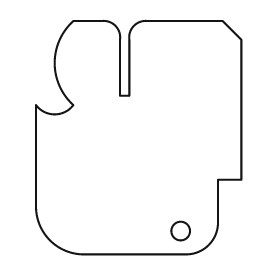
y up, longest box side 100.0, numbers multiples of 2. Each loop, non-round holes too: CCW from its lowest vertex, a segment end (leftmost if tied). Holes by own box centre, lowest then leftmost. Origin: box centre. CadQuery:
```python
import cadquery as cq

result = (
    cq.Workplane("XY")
    .moveTo(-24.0, -50.0)
    .lineTo(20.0, -50.0)
    .threePointArc((30.0, -46.0), (34.0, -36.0))
    .lineTo(34.0, -18.0)
    .lineTo(44.0, -18.0)
    .lineTo(44.0, 42.0)
    .lineTo(36.0, 50.0)
    .lineTo(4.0, 50.0)
    .threePointArc((-2.0, 48.0), (-4.0, 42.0))
    .lineTo(-4.0, 18.0)
    .lineTo(-8.0, 18.0)
    .lineTo(-8.0, 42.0)
    .threePointArc((-10.0, 48.0), (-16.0, 50.0))
    .lineTo(-28.0, 50.0)
    .threePointArc((-36.0, 32.0), (-28.0, 14.0))
    .threePointArc((-36.0, 10.0), (-44.0, 14.0))
    .lineTo(-44.0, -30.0)
    .threePointArc((-38.0, -44.0), (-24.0, -50.0))
    .close()
    .moveTo(18.0, -40.0)
    .circle(4.0)
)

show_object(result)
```